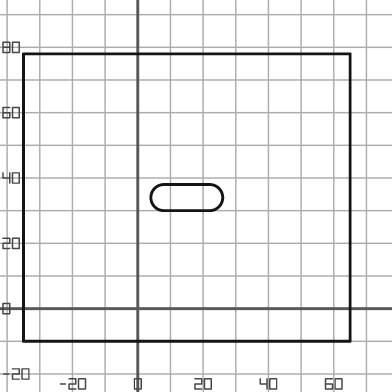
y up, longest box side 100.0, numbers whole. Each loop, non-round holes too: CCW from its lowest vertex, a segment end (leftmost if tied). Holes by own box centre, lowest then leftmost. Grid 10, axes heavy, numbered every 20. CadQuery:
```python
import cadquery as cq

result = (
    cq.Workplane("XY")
    .moveTo(-35.0, -10.0)
    .lineTo(65.0, -10.0)
    .lineTo(65.0, 78.0)
    .lineTo(-35.0, 78.0)
    .close()
    .moveTo(8.0, 30.0)
    .lineTo(22.0, 30.0)
    .threePointArc((26.0, 34.0), (22.0, 38.0))
    .lineTo(8.0, 38.0)
    .threePointArc((4.0, 34.0), (8.0, 30.0))
    .close()
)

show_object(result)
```